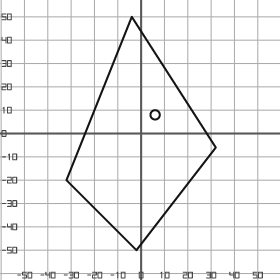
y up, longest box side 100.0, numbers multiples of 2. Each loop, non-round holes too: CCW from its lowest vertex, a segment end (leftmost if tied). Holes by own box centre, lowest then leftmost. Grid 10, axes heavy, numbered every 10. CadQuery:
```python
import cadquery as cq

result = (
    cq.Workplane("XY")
    .moveTo(-2.0, -50.0)
    .lineTo(32.0, -6.0)
    .lineTo(-4.0, 50.0)
    .lineTo(-32.0, -20.0)
    .close()
    .moveTo(6.0, 8.0)
    .circle(2.0)
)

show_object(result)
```